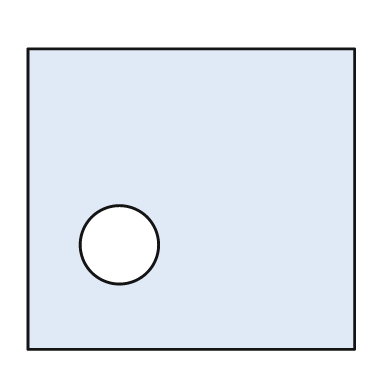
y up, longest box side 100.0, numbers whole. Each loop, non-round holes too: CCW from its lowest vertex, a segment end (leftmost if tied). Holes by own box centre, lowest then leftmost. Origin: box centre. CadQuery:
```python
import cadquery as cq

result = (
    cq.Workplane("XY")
    .moveTo(-50.0, -46.0)
    .lineTo(50.0, -46.0)
    .lineTo(50.0, 46.0)
    .lineTo(-50.0, 46.0)
    .close()
    .moveTo(-22.0, -14.0)
    .circle(12.0)
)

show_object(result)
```